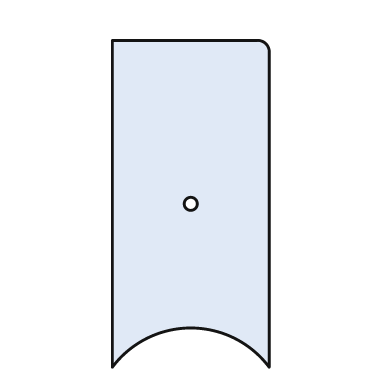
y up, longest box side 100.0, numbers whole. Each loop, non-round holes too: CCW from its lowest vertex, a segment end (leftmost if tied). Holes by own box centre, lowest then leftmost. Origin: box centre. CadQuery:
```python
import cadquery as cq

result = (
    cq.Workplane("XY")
    .moveTo(-24.0, -50.0)
    .threePointArc((0.0, -38.0), (24.0, -50.0))
    .lineTo(24.0, 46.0)
    .threePointArc((23.0, 49.0), (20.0, 50.0))
    .lineTo(-24.0, 50.0)
    .close()
    .moveTo(0.0, 0.0)
    .circle(2.0)
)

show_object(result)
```